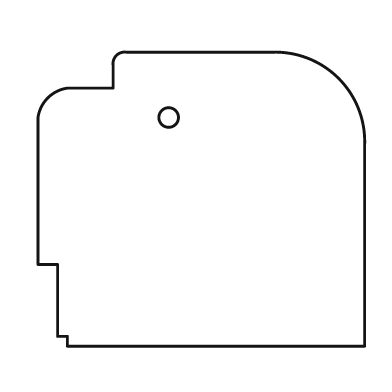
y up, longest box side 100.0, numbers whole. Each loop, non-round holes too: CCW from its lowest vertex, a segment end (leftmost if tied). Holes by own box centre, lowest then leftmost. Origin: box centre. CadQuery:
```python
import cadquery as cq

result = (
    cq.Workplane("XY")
    .moveTo(-41.0, -45.0)
    .lineTo(50.0, -45.0)
    .lineTo(50.0, 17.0)
    .threePointArc((42.0, 37.0), (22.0, 45.0))
    .lineTo(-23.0, 45.0)
    .threePointArc((-26.0, 44.0), (-27.0, 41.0))
    .lineTo(-27.0, 34.0)
    .lineTo(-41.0, 34.0)
    .threePointArc((-47.0, 31.0), (-50.0, 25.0))
    .lineTo(-50.0, -20.0)
    .lineTo(-44.0, -20.0)
    .lineTo(-44.0, -42.0)
    .lineTo(-41.0, -42.0)
    .close()
    .moveTo(-10.0, 25.0)
    .circle(3.0)
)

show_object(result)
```